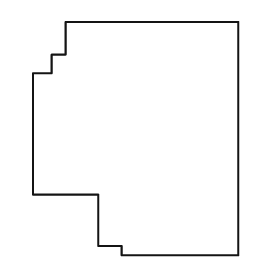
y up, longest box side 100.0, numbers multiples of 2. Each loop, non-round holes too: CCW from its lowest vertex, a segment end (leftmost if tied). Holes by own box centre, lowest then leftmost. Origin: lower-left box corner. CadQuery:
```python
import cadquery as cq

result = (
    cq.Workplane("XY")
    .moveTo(38.0, 0.0)
    .lineTo(88.0, 0.0)
    .lineTo(88.0, 100.0)
    .lineTo(14.0, 100.0)
    .lineTo(14.0, 86.0)
    .lineTo(8.0, 86.0)
    .lineTo(8.0, 78.0)
    .lineTo(0.0, 78.0)
    .lineTo(0.0, 26.0)
    .lineTo(28.0, 26.0)
    .lineTo(28.0, 4.0)
    .lineTo(38.0, 4.0)
    .close()
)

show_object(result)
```